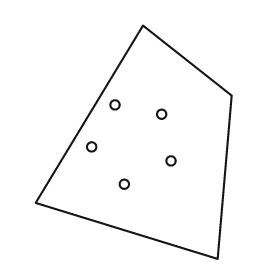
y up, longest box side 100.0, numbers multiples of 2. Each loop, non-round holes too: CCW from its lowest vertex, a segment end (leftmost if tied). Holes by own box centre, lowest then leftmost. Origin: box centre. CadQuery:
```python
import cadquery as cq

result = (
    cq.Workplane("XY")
    .moveTo(36.0, -50.0)
    .lineTo(42.0, 20.0)
    .lineTo(4.0, 50.0)
    .lineTo(-42.0, -26.0)
    .close()
    .moveTo(-4.0, -18.0)
    .circle(2.0)
    .moveTo(16.0, -8.0)
    .circle(2.0)
    .moveTo(-18.0, -2.0)
    .circle(2.0)
    .moveTo(12.0, 12.0)
    .circle(2.0)
    .moveTo(-8.0, 16.0)
    .circle(2.0)
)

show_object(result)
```